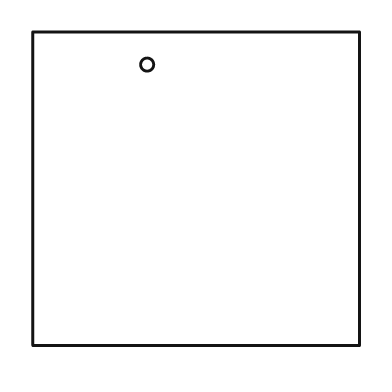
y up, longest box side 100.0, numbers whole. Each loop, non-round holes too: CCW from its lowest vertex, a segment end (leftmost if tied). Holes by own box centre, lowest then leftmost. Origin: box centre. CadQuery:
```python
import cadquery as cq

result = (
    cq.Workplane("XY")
    .moveTo(-50.0, -48.0)
    .lineTo(50.0, -48.0)
    .lineTo(50.0, 48.0)
    .lineTo(-50.0, 48.0)
    .close()
    .moveTo(-15.0, 38.0)
    .circle(2.0)
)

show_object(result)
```